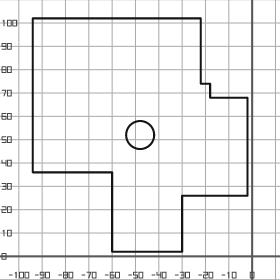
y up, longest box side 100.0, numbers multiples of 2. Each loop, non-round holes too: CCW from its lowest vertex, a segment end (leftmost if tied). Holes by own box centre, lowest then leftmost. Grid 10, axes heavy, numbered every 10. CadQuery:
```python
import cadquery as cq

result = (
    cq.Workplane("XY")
    .moveTo(-60.0, 2.0)
    .lineTo(-30.0, 2.0)
    .lineTo(-30.0, 26.0)
    .lineTo(-2.0, 26.0)
    .lineTo(-2.0, 68.0)
    .lineTo(-18.0, 68.0)
    .lineTo(-18.0, 74.0)
    .lineTo(-22.0, 74.0)
    .lineTo(-22.0, 102.0)
    .lineTo(-94.0, 102.0)
    .lineTo(-94.0, 36.0)
    .lineTo(-60.0, 36.0)
    .close()
    .moveTo(-48.0, 52.0)
    .circle(6.0)
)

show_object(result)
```